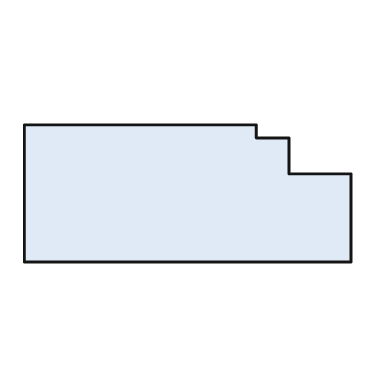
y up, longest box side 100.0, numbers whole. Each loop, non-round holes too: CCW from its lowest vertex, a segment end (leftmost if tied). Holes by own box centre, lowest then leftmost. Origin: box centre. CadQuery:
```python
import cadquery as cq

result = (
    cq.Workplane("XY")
    .moveTo(-50.0, -21.0)
    .lineTo(50.0, -21.0)
    .lineTo(50.0, 6.0)
    .lineTo(31.0, 6.0)
    .lineTo(31.0, 17.0)
    .lineTo(21.0, 17.0)
    .lineTo(21.0, 21.0)
    .lineTo(-50.0, 21.0)
    .close()
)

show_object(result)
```